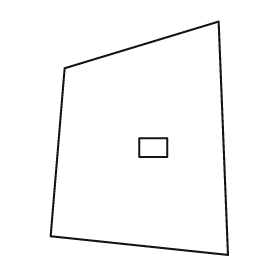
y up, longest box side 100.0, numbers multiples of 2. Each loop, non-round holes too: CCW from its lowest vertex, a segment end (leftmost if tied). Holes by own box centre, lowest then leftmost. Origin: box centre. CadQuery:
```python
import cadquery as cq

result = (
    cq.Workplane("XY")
    .moveTo(38.0, -50.0)
    .lineTo(34.0, 50.0)
    .lineTo(-32.0, 30.0)
    .lineTo(-38.0, -42.0)
    .close()
    .moveTo(0.0, -8.0)
    .lineTo(12.0, -8.0)
    .lineTo(12.0, 0.0)
    .lineTo(0.0, 0.0)
    .close()
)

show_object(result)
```